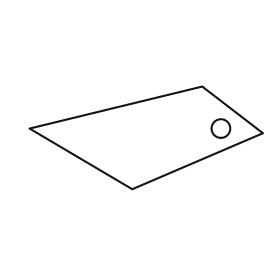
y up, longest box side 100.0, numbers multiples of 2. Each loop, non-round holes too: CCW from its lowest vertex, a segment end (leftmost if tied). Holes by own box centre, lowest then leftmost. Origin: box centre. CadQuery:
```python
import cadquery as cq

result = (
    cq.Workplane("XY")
    .moveTo(-6.0, -22.0)
    .lineTo(50.0, 2.0)
    .lineTo(24.0, 22.0)
    .lineTo(-50.0, 4.0)
    .close()
    .moveTo(32.0, 4.0)
    .circle(4.0)
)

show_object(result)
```